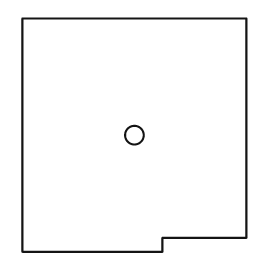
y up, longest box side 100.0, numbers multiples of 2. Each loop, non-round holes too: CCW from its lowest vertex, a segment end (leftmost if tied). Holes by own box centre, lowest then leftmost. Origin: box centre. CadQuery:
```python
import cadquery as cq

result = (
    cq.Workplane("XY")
    .moveTo(-48.0, -50.0)
    .lineTo(12.0, -50.0)
    .lineTo(12.0, -44.0)
    .lineTo(48.0, -44.0)
    .lineTo(48.0, 50.0)
    .lineTo(-48.0, 50.0)
    .close()
    .moveTo(0.0, 0.0)
    .circle(4.0)
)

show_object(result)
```